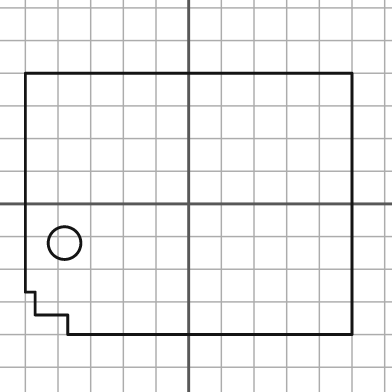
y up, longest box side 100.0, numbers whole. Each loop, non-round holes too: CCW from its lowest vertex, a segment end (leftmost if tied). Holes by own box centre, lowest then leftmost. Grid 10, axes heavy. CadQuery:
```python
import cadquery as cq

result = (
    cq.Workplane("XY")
    .moveTo(-37.0, -40.0)
    .lineTo(50.0, -40.0)
    .lineTo(50.0, 40.0)
    .lineTo(-50.0, 40.0)
    .lineTo(-50.0, -27.0)
    .lineTo(-47.0, -27.0)
    .lineTo(-47.0, -34.0)
    .lineTo(-37.0, -34.0)
    .close()
    .moveTo(-38.0, -12.0)
    .circle(5.0)
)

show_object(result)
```